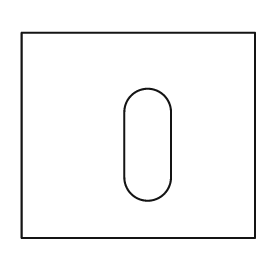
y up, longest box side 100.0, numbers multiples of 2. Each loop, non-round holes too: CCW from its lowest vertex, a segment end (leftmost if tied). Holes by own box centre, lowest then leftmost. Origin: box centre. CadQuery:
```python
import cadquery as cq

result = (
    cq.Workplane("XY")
    .moveTo(-50.0, -44.0)
    .lineTo(50.0, -44.0)
    .lineTo(50.0, 44.0)
    .lineTo(-50.0, 44.0)
    .close()
    .moveTo(-6.0, -18.0)
    .threePointArc((4.0, -28.0), (14.0, -18.0))
    .lineTo(14.0, 10.0)
    .threePointArc((4.0, 20.0), (-6.0, 10.0))
    .close()
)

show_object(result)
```